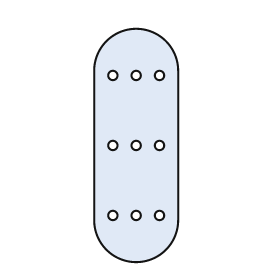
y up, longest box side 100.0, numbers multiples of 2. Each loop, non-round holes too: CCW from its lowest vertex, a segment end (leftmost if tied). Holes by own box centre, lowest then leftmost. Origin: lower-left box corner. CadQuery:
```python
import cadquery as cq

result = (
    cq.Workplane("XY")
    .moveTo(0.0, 18.0)
    .threePointArc((18.0, 0.0), (36.0, 18.0))
    .lineTo(36.0, 82.0)
    .threePointArc((18.0, 100.0), (0.0, 82.0))
    .close()
    .moveTo(8.0, 20.0)
    .circle(2.0)
    .moveTo(18.0, 20.0)
    .circle(2.0)
    .moveTo(28.0, 20.0)
    .circle(2.0)
    .moveTo(8.0, 50.0)
    .circle(2.0)
    .moveTo(18.0, 50.0)
    .circle(2.0)
    .moveTo(28.0, 50.0)
    .circle(2.0)
    .moveTo(8.0, 80.0)
    .circle(2.0)
    .moveTo(18.0, 80.0)
    .circle(2.0)
    .moveTo(28.0, 80.0)
    .circle(2.0)
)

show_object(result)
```